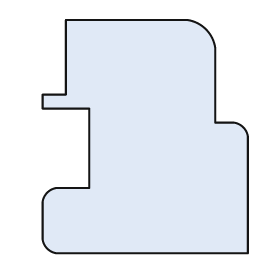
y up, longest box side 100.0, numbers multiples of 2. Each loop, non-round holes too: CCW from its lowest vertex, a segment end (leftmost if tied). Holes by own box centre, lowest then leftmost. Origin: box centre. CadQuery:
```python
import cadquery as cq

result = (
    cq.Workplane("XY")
    .moveTo(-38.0, -50.0)
    .lineTo(44.0, -50.0)
    .lineTo(44.0, 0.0)
    .threePointArc((42.0, 4.0), (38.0, 6.0))
    .lineTo(30.0, 6.0)
    .lineTo(30.0, 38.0)
    .threePointArc((26.0, 46.0), (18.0, 50.0))
    .lineTo(-34.0, 50.0)
    .lineTo(-34.0, 18.0)
    .lineTo(-44.0, 18.0)
    .lineTo(-44.0, 12.0)
    .lineTo(-24.0, 12.0)
    .lineTo(-24.0, -22.0)
    .lineTo(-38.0, -22.0)
    .threePointArc((-42.0, -24.0), (-44.0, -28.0))
    .lineTo(-44.0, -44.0)
    .threePointArc((-42.0, -48.0), (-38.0, -50.0))
    .close()
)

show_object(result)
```